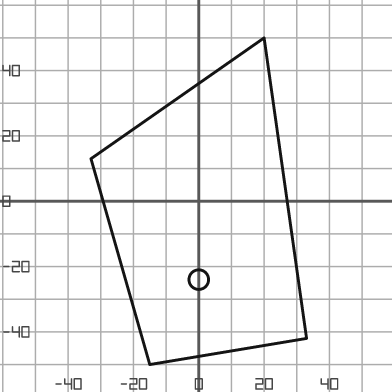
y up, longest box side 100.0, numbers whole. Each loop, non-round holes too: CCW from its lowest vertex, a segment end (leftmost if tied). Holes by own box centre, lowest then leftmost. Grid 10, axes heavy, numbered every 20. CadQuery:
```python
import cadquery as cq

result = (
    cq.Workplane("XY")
    .moveTo(-15.0, -50.0)
    .lineTo(33.0, -42.0)
    .lineTo(20.0, 50.0)
    .lineTo(-33.0, 13.0)
    .close()
    .moveTo(0.0, -24.0)
    .circle(3.0)
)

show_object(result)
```